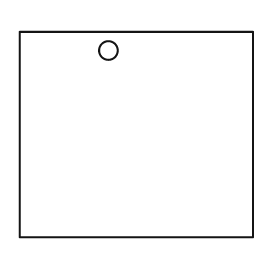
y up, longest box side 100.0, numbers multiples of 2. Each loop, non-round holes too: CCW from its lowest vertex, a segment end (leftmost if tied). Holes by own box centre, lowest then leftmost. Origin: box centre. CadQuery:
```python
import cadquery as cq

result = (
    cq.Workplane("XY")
    .moveTo(-50.0, -44.0)
    .lineTo(50.0, -44.0)
    .lineTo(50.0, 44.0)
    .lineTo(-50.0, 44.0)
    .close()
    .moveTo(-12.0, 36.0)
    .circle(4.0)
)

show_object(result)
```